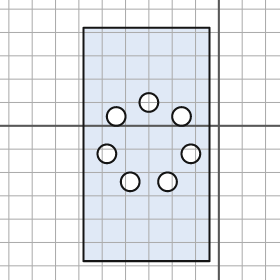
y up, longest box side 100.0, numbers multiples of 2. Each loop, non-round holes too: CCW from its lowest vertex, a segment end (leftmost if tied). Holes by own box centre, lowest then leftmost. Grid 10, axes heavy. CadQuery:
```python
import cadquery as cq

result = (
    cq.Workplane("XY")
    .moveTo(-58.0, -58.0)
    .lineTo(-4.0, -58.0)
    .lineTo(-4.0, 42.0)
    .lineTo(-58.0, 42.0)
    .close()
    .moveTo(-38.0, -24.0)
    .circle(4.0)
    .moveTo(-22.0, -24.0)
    .circle(4.0)
    .moveTo(-48.0, -12.0)
    .circle(4.0)
    .moveTo(-12.0, -12.0)
    .circle(4.0)
    .moveTo(-44.0, 4.0)
    .circle(4.0)
    .moveTo(-16.0, 4.0)
    .circle(4.0)
    .moveTo(-30.0, 10.0)
    .circle(4.0)
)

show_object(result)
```